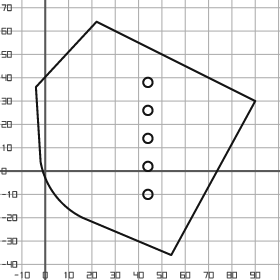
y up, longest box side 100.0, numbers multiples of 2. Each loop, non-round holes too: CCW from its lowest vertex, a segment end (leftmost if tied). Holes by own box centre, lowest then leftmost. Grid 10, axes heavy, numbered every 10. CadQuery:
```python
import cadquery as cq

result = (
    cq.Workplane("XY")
    .moveTo(54.0, -36.0)
    .lineTo(90.0, 30.0)
    .lineTo(22.0, 64.0)
    .lineTo(-4.0, 36.0)
    .lineTo(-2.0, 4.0)
    .threePointArc((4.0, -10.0), (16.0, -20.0))
    .close()
    .moveTo(44.0, -10.0)
    .circle(2.0)
    .moveTo(44.0, 2.0)
    .circle(2.0)
    .moveTo(44.0, 14.0)
    .circle(2.0)
    .moveTo(44.0, 26.0)
    .circle(2.0)
    .moveTo(44.0, 38.0)
    .circle(2.0)
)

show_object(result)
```